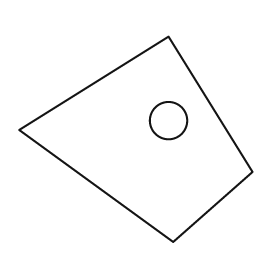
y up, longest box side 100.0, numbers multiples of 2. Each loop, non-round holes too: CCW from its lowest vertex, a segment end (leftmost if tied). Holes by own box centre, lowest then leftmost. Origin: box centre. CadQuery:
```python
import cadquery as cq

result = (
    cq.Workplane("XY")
    .moveTo(16.0, -44.0)
    .lineTo(50.0, -14.0)
    .lineTo(14.0, 44.0)
    .lineTo(-50.0, 4.0)
    .close()
    .moveTo(14.0, 8.0)
    .circle(8.0)
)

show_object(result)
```